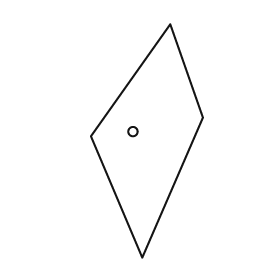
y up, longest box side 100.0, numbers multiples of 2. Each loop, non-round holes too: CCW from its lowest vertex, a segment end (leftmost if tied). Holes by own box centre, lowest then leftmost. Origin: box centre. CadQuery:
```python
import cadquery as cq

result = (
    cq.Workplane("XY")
    .moveTo(-2.0, -50.0)
    .lineTo(24.0, 10.0)
    .lineTo(10.0, 50.0)
    .lineTo(-24.0, 2.0)
    .close()
    .moveTo(-6.0, 4.0)
    .circle(2.0)
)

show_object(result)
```